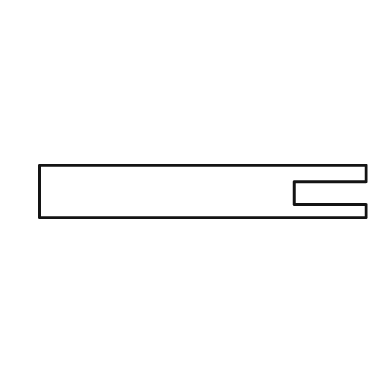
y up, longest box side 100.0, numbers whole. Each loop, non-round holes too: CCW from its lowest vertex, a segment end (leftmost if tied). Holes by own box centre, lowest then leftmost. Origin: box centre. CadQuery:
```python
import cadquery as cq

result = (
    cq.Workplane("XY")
    .moveTo(-50.0, -8.0)
    .lineTo(50.0, -8.0)
    .lineTo(50.0, -4.0)
    .lineTo(28.0, -4.0)
    .lineTo(28.0, 3.0)
    .lineTo(50.0, 3.0)
    .lineTo(50.0, 8.0)
    .lineTo(-50.0, 8.0)
    .close()
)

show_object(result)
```